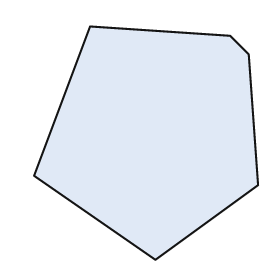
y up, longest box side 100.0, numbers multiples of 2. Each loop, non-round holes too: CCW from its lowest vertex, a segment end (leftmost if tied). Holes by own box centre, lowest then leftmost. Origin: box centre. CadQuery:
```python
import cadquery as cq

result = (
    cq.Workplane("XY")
    .moveTo(4.0, -50.0)
    .lineTo(48.0, -18.0)
    .lineTo(44.0, 38.0)
    .lineTo(36.0, 46.0)
    .lineTo(-24.0, 50.0)
    .lineTo(-48.0, -14.0)
    .close()
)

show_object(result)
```